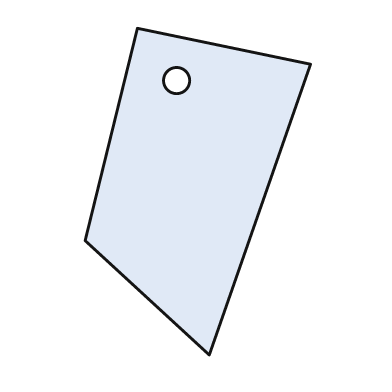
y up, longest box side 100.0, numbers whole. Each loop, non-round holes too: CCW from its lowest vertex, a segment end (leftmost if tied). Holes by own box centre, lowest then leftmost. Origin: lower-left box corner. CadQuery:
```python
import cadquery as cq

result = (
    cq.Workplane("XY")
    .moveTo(38.0, 0.0)
    .lineTo(69.0, 89.0)
    .lineTo(16.0, 100.0)
    .lineTo(0.0, 35.0)
    .close()
    .moveTo(28.0, 84.0)
    .circle(4.0)
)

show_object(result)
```